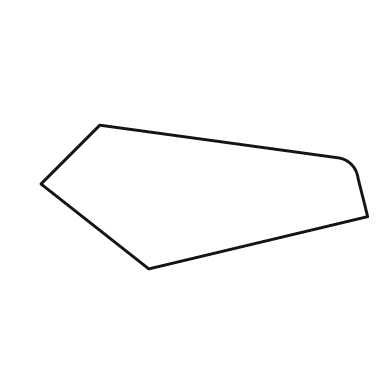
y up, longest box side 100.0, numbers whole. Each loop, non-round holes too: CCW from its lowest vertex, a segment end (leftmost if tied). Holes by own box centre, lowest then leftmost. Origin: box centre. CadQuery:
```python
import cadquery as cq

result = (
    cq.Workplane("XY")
    .moveTo(-17.0, -22.0)
    .lineTo(50.0, -6.0)
    .lineTo(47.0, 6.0)
    .threePointArc((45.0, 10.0), (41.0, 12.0))
    .lineTo(-32.0, 22.0)
    .lineTo(-50.0, 4.0)
    .close()
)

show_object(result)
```